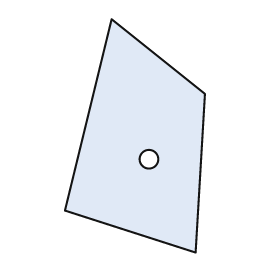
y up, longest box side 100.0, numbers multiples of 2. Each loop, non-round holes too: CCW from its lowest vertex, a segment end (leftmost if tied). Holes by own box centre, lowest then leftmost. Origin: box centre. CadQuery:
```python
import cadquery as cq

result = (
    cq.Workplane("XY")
    .moveTo(26.0, -50.0)
    .lineTo(30.0, 18.0)
    .lineTo(-10.0, 50.0)
    .lineTo(-30.0, -32.0)
    .close()
    .moveTo(6.0, -10.0)
    .circle(4.0)
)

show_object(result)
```